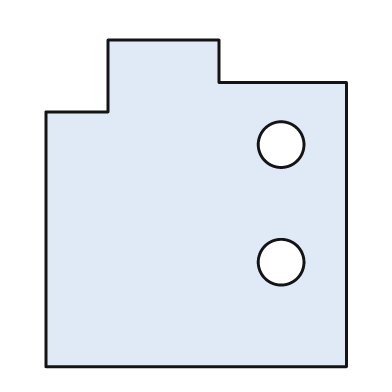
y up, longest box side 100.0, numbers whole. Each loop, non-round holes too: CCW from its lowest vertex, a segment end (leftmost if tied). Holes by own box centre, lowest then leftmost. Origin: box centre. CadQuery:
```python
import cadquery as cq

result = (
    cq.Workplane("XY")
    .moveTo(-46.0, -50.0)
    .lineTo(46.0, -50.0)
    .lineTo(46.0, 37.0)
    .lineTo(7.0, 37.0)
    .lineTo(7.0, 50.0)
    .lineTo(-27.0, 50.0)
    .lineTo(-27.0, 28.0)
    .lineTo(-46.0, 28.0)
    .close()
    .moveTo(26.0, -18.0)
    .circle(7.0)
    .moveTo(26.0, 18.0)
    .circle(7.0)
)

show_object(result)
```